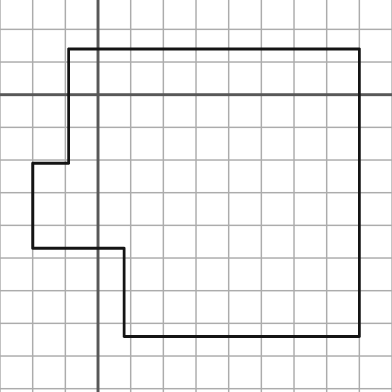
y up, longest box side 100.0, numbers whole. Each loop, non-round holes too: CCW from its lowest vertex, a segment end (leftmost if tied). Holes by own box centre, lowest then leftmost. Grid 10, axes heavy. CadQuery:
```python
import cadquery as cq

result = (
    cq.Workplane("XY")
    .moveTo(8.0, -74.0)
    .lineTo(80.0, -74.0)
    .lineTo(80.0, 14.0)
    .lineTo(-9.0, 14.0)
    .lineTo(-9.0, -21.0)
    .lineTo(-20.0, -21.0)
    .lineTo(-20.0, -47.0)
    .lineTo(8.0, -47.0)
    .close()
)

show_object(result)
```